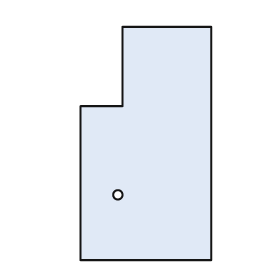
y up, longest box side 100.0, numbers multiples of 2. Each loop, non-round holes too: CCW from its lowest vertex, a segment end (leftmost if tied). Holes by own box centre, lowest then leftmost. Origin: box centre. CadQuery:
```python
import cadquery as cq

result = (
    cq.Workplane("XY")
    .moveTo(-28.0, -50.0)
    .lineTo(28.0, -50.0)
    .lineTo(28.0, 50.0)
    .lineTo(-10.0, 50.0)
    .lineTo(-10.0, 16.0)
    .lineTo(-28.0, 16.0)
    .close()
    .moveTo(-12.0, -22.0)
    .circle(2.0)
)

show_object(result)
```